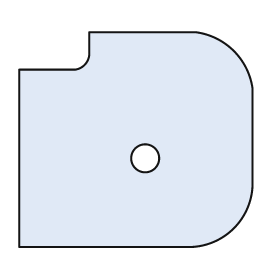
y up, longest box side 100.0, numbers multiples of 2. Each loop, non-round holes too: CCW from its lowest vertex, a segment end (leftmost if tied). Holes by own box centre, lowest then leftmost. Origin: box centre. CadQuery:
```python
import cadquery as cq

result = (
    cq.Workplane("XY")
    .moveTo(-50.0, -46.0)
    .lineTo(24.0, -46.0)
    .threePointArc((42.0, -38.0), (50.0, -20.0))
    .lineTo(50.0, 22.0)
    .threePointArc((42.0, 38.0), (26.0, 46.0))
    .lineTo(-20.0, 46.0)
    .lineTo(-20.0, 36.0)
    .threePointArc((-22.0, 32.0), (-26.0, 30.0))
    .lineTo(-50.0, 30.0)
    .close()
    .moveTo(4.0, -8.0)
    .circle(6.0)
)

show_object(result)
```